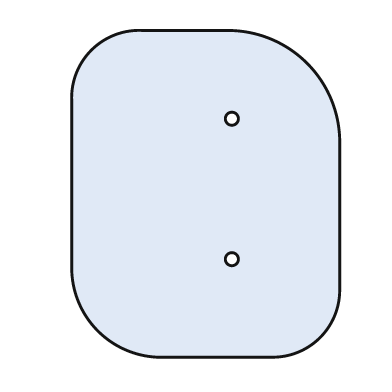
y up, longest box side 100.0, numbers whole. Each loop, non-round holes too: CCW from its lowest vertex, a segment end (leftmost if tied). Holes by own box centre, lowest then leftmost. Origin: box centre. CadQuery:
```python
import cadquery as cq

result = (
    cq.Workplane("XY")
    .moveTo(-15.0, -50.0)
    .lineTo(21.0, -50.0)
    .threePointArc((35.0, -44.0), (41.0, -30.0))
    .lineTo(41.0, 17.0)
    .threePointArc((31.0, 40.0), (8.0, 50.0))
    .lineTo(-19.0, 50.0)
    .threePointArc((-35.0, 44.0), (-41.0, 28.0))
    .lineTo(-41.0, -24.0)
    .threePointArc((-33.0, -42.0), (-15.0, -50.0))
    .close()
    .moveTo(8.0, -20.0)
    .circle(2.0)
    .moveTo(8.0, 23.0)
    .circle(2.0)
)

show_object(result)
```